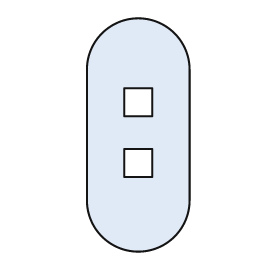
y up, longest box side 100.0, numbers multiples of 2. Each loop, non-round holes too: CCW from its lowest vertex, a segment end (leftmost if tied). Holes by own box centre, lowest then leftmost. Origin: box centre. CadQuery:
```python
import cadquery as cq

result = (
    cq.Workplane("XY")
    .moveTo(-22.0, -28.0)
    .threePointArc((0.0, -50.0), (22.0, -28.0))
    .lineTo(22.0, 28.0)
    .threePointArc((0.0, 50.0), (-22.0, 28.0))
    .close()
    .moveTo(-6.0, -18.0)
    .lineTo(6.0, -18.0)
    .lineTo(6.0, -6.0)
    .lineTo(-6.0, -6.0)
    .close()
    .moveTo(-6.0, 8.0)
    .lineTo(6.0, 8.0)
    .lineTo(6.0, 20.0)
    .lineTo(-6.0, 20.0)
    .close()
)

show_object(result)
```